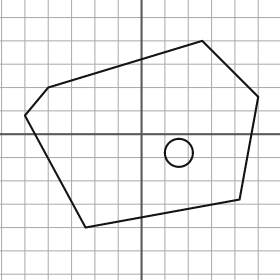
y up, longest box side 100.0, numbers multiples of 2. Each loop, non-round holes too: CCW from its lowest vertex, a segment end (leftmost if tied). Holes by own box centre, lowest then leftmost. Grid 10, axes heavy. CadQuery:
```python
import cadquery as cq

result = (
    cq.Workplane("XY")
    .moveTo(-24.0, -40.0)
    .lineTo(42.0, -28.0)
    .lineTo(50.0, 16.0)
    .lineTo(26.0, 40.0)
    .lineTo(-40.0, 20.0)
    .lineTo(-50.0, 8.0)
    .close()
    .moveTo(16.0, -8.0)
    .circle(6.0)
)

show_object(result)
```